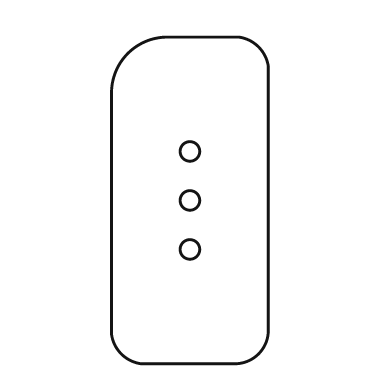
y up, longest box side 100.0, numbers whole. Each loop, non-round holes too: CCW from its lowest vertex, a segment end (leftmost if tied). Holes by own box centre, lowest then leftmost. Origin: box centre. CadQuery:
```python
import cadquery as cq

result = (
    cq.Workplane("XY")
    .moveTo(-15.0, -50.0)
    .lineTo(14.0, -50.0)
    .threePointArc((21.0, -47.0), (24.0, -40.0))
    .lineTo(24.0, 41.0)
    .threePointArc((21.0, 47.0), (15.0, 50.0))
    .lineTo(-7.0, 50.0)
    .threePointArc((-19.0, 45.0), (-24.0, 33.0))
    .lineTo(-24.0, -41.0)
    .threePointArc((-21.0, -47.0), (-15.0, -50.0))
    .close()
    .moveTo(0.0, -15.0)
    .circle(3.0)
    .moveTo(0.0, 0.0)
    .circle(3.0)
    .moveTo(0.0, 15.0)
    .circle(3.0)
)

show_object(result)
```